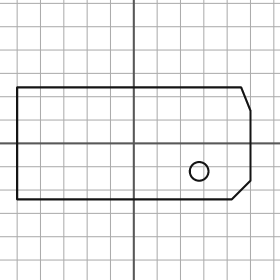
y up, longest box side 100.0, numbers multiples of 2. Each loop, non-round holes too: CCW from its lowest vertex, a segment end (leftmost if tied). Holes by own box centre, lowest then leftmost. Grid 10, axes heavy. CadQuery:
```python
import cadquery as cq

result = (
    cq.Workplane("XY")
    .moveTo(-50.0, -24.0)
    .lineTo(42.0, -24.0)
    .lineTo(50.0, -16.0)
    .lineTo(50.0, 14.0)
    .lineTo(46.0, 24.0)
    .lineTo(-50.0, 24.0)
    .close()
    .moveTo(28.0, -12.0)
    .circle(4.0)
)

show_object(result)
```